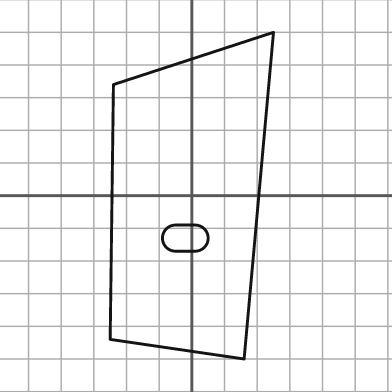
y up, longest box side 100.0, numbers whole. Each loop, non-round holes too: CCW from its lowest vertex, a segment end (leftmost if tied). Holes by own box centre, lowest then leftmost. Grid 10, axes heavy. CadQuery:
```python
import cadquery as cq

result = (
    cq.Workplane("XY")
    .moveTo(16.0, -50.0)
    .lineTo(25.0, 50.0)
    .lineTo(-24.0, 34.0)
    .lineTo(-25.0, -44.0)
    .close()
    .moveTo(-5.0, -17.0)
    .lineTo(1.0, -17.0)
    .threePointArc((5.0, -13.0), (1.0, -9.0))
    .lineTo(-5.0, -9.0)
    .threePointArc((-9.0, -13.0), (-5.0, -17.0))
    .close()
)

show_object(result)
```